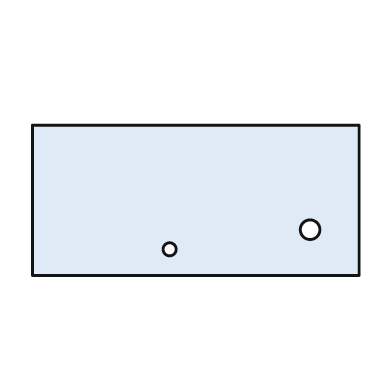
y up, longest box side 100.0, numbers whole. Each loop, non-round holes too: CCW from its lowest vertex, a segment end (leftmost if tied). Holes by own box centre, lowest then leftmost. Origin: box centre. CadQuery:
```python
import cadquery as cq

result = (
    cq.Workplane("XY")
    .moveTo(-50.0, -23.0)
    .lineTo(50.0, -23.0)
    .lineTo(50.0, 23.0)
    .lineTo(-50.0, 23.0)
    .close()
    .moveTo(-8.0, -15.0)
    .circle(2.0)
    .moveTo(35.0, -9.0)
    .circle(3.0)
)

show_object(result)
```